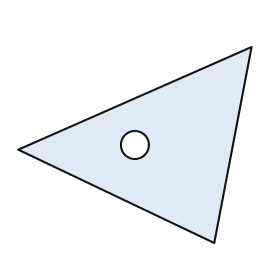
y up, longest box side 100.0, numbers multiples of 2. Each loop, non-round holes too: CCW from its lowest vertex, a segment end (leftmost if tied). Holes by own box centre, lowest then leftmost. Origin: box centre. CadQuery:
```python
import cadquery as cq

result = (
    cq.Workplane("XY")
    .moveTo(34.0, -42.0)
    .lineTo(50.0, 42.0)
    .lineTo(-50.0, -2.0)
    .close()
    .moveTo(0.0, 0.0)
    .circle(6.0)
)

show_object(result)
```